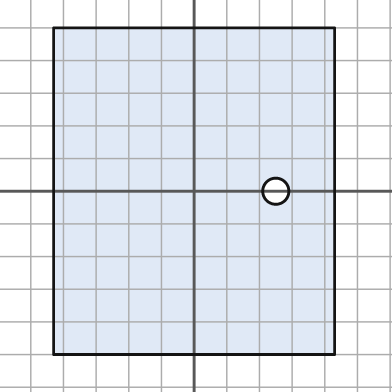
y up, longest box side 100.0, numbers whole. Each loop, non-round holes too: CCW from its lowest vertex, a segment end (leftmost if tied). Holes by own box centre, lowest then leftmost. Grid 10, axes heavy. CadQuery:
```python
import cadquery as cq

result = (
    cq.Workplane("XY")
    .moveTo(-43.0, -50.0)
    .lineTo(43.0, -50.0)
    .lineTo(43.0, 50.0)
    .lineTo(-43.0, 50.0)
    .close()
    .moveTo(25.0, 0.0)
    .circle(4.0)
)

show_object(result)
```